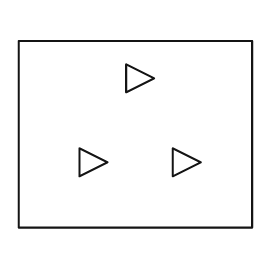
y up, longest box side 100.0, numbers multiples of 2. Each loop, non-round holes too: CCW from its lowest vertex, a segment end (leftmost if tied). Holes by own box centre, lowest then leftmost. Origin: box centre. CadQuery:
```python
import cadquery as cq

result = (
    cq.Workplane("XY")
    .moveTo(-50.0, -40.0)
    .lineTo(50.0, -40.0)
    .lineTo(50.0, 40.0)
    .lineTo(-50.0, 40.0)
    .close()
    .moveTo(-24.0, -18.0)
    .lineTo(-12.0, -12.0)
    .lineTo(-24.0, -6.0)
    .close()
    .moveTo(16.0, -18.0)
    .lineTo(28.0, -12.0)
    .lineTo(16.0, -6.0)
    .close()
    .moveTo(-4.0, 18.0)
    .lineTo(8.0, 24.0)
    .lineTo(-4.0, 30.0)
    .close()
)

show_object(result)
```